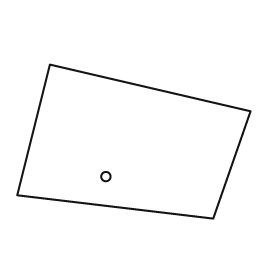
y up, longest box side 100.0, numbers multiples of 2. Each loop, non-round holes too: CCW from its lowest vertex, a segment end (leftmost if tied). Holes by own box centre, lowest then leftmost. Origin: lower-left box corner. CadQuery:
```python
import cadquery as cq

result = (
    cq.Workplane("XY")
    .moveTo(84.0, 0.0)
    .lineTo(100.0, 46.0)
    .lineTo(14.0, 66.0)
    .lineTo(0.0, 10.0)
    .close()
    .moveTo(38.0, 18.0)
    .circle(2.0)
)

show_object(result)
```